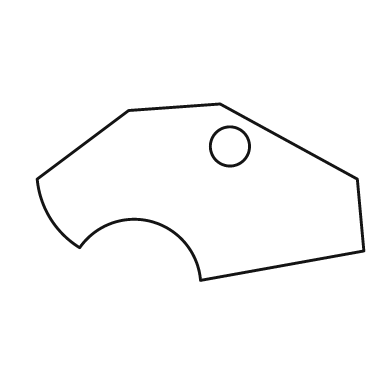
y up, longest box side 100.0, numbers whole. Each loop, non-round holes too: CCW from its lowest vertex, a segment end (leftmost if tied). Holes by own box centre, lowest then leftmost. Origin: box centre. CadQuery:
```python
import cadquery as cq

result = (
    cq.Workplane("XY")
    .moveTo(0.0, -27.0)
    .lineTo(50.0, -18.0)
    .lineTo(48.0, 4.0)
    .lineTo(6.0, 27.0)
    .lineTo(-22.0, 25.0)
    .lineTo(-50.0, 4.0)
    .threePointArc((-46.0, -8.0), (-37.0, -17.0))
    .threePointArc((-15.0, -9.0), (0.0, -27.0))
    .close()
    .moveTo(9.0, 14.0)
    .circle(6.0)
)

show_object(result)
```